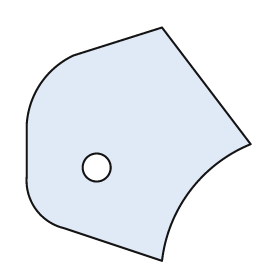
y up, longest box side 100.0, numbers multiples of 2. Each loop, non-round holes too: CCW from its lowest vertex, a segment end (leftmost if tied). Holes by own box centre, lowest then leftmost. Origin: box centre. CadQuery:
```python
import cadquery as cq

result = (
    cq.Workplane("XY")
    .moveTo(10.0, -50.0)
    .threePointArc((22.0, -20.0), (48.0, 0.0))
    .lineTo(10.0, 50.0)
    .lineTo(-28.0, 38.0)
    .threePointArc((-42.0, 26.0), (-48.0, 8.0))
    .lineTo(-48.0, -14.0)
    .threePointArc((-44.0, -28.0), (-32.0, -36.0))
    .close()
    .moveTo(-18.0, -10.0)
    .circle(6.0)
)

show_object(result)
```